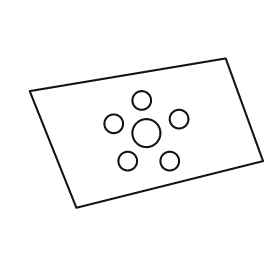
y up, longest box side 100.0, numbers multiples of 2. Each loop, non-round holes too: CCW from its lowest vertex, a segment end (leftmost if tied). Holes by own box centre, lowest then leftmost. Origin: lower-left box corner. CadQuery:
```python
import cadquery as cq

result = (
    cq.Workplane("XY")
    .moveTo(20.0, 0.0)
    .lineTo(100.0, 20.0)
    .lineTo(84.0, 64.0)
    .lineTo(0.0, 50.0)
    .close()
    .moveTo(42.0, 20.0)
    .circle(4.0)
    .moveTo(60.0, 20.0)
    .circle(4.0)
    .moveTo(50.0, 32.0)
    .circle(6.0)
    .moveTo(36.0, 36.0)
    .circle(4.0)
    .moveTo(64.0, 38.0)
    .circle(4.0)
    .moveTo(48.0, 46.0)
    .circle(4.0)
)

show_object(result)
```